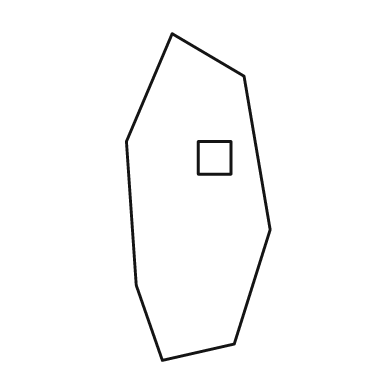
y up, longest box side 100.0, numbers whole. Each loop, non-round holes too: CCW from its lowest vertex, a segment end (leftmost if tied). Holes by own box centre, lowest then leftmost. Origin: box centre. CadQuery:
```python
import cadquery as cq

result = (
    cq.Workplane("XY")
    .moveTo(-11.0, -50.0)
    .lineTo(11.0, -45.0)
    .lineTo(22.0, -10.0)
    .lineTo(14.0, 37.0)
    .lineTo(-8.0, 50.0)
    .lineTo(-22.0, 17.0)
    .lineTo(-19.0, -27.0)
    .close()
    .moveTo(0.0, 7.0)
    .lineTo(10.0, 7.0)
    .lineTo(10.0, 17.0)
    .lineTo(0.0, 17.0)
    .close()
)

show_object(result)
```